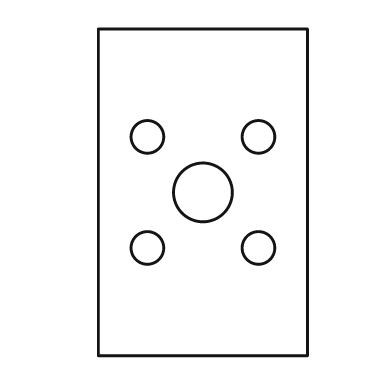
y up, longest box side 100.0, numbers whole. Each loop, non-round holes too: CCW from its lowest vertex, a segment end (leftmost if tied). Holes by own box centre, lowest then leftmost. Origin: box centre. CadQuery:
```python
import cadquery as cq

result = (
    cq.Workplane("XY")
    .moveTo(-32.0, -50.0)
    .lineTo(32.0, -50.0)
    .lineTo(32.0, 50.0)
    .lineTo(-32.0, 50.0)
    .close()
    .moveTo(-17.0, -17.0)
    .circle(5.0)
    .moveTo(17.0, -17.0)
    .circle(5.0)
    .moveTo(0.0, 0.0)
    .circle(9.0)
    .moveTo(-17.0, 17.0)
    .circle(5.0)
    .moveTo(17.0, 17.0)
    .circle(5.0)
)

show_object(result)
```